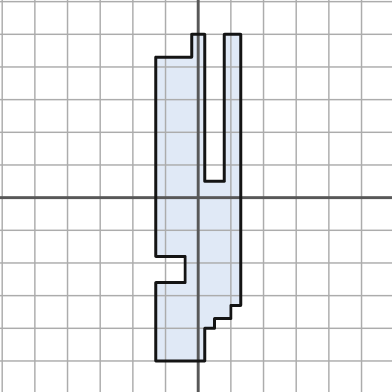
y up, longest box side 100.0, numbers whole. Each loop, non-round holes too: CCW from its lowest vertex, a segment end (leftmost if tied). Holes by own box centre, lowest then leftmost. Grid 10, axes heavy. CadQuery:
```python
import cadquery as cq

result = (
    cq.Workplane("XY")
    .moveTo(-13.0, -50.0)
    .lineTo(2.0, -50.0)
    .lineTo(2.0, -40.0)
    .lineTo(5.0, -40.0)
    .lineTo(5.0, -37.0)
    .lineTo(10.0, -37.0)
    .lineTo(10.0, -33.0)
    .lineTo(13.0, -33.0)
    .lineTo(13.0, 50.0)
    .lineTo(8.0, 50.0)
    .lineTo(8.0, 5.0)
    .lineTo(2.0, 5.0)
    .lineTo(2.0, 50.0)
    .lineTo(-2.0, 50.0)
    .lineTo(-2.0, 43.0)
    .lineTo(-13.0, 43.0)
    .lineTo(-13.0, -18.0)
    .lineTo(-4.0, -18.0)
    .lineTo(-4.0, -26.0)
    .lineTo(-13.0, -26.0)
    .close()
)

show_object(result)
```